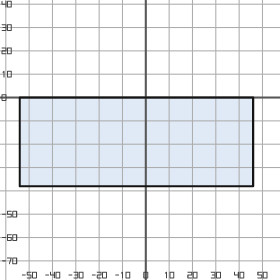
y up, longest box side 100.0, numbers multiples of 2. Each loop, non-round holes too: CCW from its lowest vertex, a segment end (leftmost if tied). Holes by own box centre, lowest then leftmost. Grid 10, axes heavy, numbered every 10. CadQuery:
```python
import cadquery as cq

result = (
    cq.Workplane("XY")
    .moveTo(-54.0, -38.0)
    .lineTo(46.0, -38.0)
    .lineTo(46.0, 0.0)
    .lineTo(-54.0, 0.0)
    .close()
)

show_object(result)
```